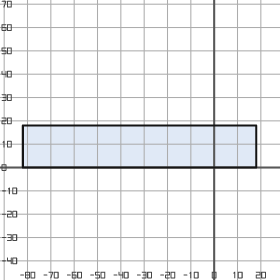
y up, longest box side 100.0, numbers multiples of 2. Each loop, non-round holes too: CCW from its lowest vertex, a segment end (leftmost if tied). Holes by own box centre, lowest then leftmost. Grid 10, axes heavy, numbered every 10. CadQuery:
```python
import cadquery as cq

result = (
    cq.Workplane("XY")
    .moveTo(-82.0, 0.0)
    .lineTo(18.0, 0.0)
    .lineTo(18.0, 18.0)
    .lineTo(-82.0, 18.0)
    .close()
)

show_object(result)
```